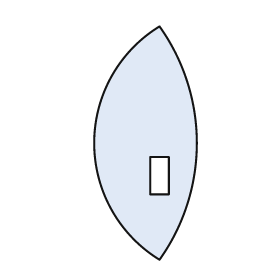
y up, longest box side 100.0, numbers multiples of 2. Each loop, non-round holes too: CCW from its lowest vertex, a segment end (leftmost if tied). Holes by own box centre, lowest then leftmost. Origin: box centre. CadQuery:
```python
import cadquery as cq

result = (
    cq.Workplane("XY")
    .moveTo(6.0, -50.0)
    .threePointArc((22.0, 0.0), (6.0, 50.0))
    .threePointArc((-22.0, 0.0), (6.0, -50.0))
    .close()
    .moveTo(2.0, -22.0)
    .lineTo(10.0, -22.0)
    .lineTo(10.0, -6.0)
    .lineTo(2.0, -6.0)
    .close()
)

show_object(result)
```